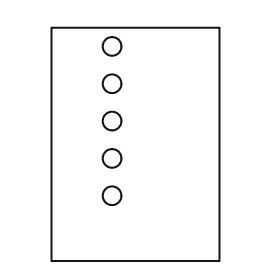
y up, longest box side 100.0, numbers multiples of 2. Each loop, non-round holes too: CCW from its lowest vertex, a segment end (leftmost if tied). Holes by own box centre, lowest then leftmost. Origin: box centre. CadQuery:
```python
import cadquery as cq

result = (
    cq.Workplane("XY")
    .moveTo(-36.0, -50.0)
    .lineTo(36.0, -50.0)
    .lineTo(36.0, 50.0)
    .lineTo(-36.0, 50.0)
    .close()
    .moveTo(-10.0, -22.0)
    .circle(4.0)
    .moveTo(-10.0, -6.0)
    .circle(4.0)
    .moveTo(-10.0, 10.0)
    .circle(4.0)
    .moveTo(-10.0, 26.0)
    .circle(4.0)
    .moveTo(-10.0, 42.0)
    .circle(4.0)
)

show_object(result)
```